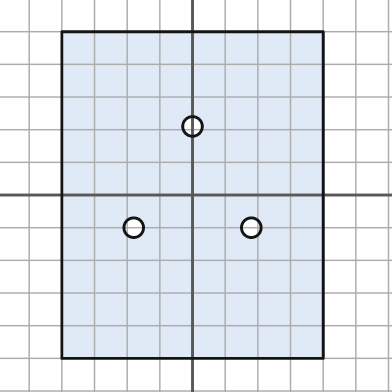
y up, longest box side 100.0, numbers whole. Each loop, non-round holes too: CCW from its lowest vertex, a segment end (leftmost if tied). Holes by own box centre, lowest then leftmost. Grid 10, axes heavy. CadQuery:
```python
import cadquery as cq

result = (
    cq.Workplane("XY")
    .moveTo(-40.0, -50.0)
    .lineTo(40.0, -50.0)
    .lineTo(40.0, 50.0)
    .lineTo(-40.0, 50.0)
    .close()
    .moveTo(-18.0, -10.0)
    .circle(3.0)
    .moveTo(18.0, -10.0)
    .circle(3.0)
    .moveTo(0.0, 21.0)
    .circle(3.0)
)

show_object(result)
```